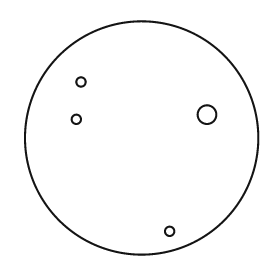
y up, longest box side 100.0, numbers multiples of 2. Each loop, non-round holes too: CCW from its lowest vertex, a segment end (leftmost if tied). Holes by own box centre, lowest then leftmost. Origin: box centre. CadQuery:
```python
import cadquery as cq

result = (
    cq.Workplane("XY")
    .moveTo(0.0, 0.0)
    .circle(50.0)
    .moveTo(12.0, -40.0)
    .circle(2.0)
    .moveTo(-28.0, 8.0)
    .circle(2.0)
    .moveTo(28.0, 10.0)
    .circle(4.0)
    .moveTo(-26.0, 24.0)
    .circle(2.0)
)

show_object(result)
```